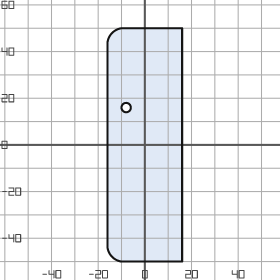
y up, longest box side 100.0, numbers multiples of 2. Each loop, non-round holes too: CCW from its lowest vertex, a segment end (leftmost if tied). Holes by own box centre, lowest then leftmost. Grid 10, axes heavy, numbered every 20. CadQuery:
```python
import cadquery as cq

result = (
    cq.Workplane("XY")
    .moveTo(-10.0, -50.0)
    .lineTo(16.0, -50.0)
    .lineTo(16.0, 50.0)
    .lineTo(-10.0, 50.0)
    .threePointArc((-14.0, 48.0), (-16.0, 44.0))
    .lineTo(-16.0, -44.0)
    .threePointArc((-14.0, -48.0), (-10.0, -50.0))
    .close()
    .moveTo(-8.0, 16.0)
    .circle(2.0)
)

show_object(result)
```